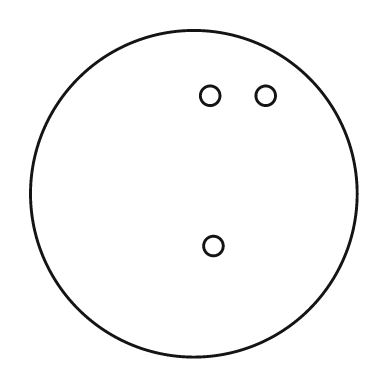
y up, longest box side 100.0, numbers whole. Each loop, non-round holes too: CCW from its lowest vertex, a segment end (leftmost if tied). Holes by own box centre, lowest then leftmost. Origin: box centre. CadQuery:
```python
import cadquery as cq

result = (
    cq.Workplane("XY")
    .moveTo(0.0, 0.0)
    .circle(50.0)
    .moveTo(6.0, -16.0)
    .circle(3.0)
    .moveTo(5.0, 30.0)
    .circle(3.0)
    .moveTo(22.0, 30.0)
    .circle(3.0)
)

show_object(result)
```